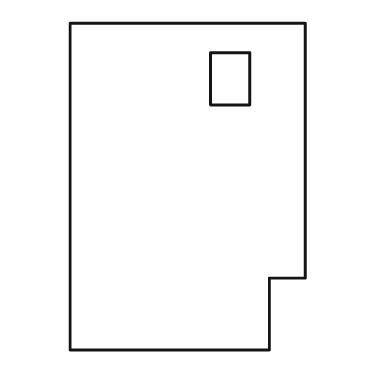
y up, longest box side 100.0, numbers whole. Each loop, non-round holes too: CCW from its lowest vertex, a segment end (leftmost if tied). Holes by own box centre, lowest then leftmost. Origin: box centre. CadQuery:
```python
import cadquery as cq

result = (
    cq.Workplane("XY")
    .moveTo(-36.0, -50.0)
    .lineTo(25.0, -50.0)
    .lineTo(25.0, -28.0)
    .lineTo(36.0, -28.0)
    .lineTo(36.0, 50.0)
    .lineTo(-36.0, 50.0)
    .close()
    .moveTo(7.0, 25.0)
    .lineTo(19.0, 25.0)
    .lineTo(19.0, 41.0)
    .lineTo(7.0, 41.0)
    .close()
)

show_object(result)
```